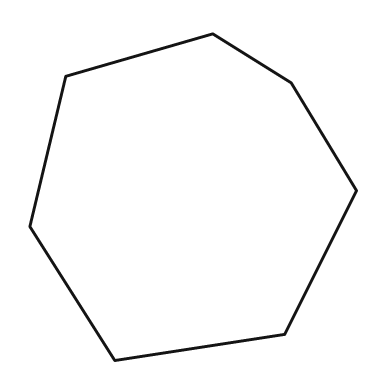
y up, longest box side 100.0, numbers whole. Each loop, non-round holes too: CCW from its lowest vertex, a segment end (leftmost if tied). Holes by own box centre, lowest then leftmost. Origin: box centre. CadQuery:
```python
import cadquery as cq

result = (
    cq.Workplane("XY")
    .moveTo(-24.0, -50.0)
    .lineTo(28.0, -42.0)
    .lineTo(50.0, 2.0)
    .lineTo(30.0, 35.0)
    .lineTo(6.0, 50.0)
    .lineTo(-39.0, 37.0)
    .lineTo(-50.0, -9.0)
    .close()
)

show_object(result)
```